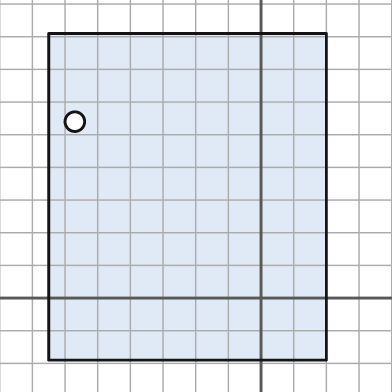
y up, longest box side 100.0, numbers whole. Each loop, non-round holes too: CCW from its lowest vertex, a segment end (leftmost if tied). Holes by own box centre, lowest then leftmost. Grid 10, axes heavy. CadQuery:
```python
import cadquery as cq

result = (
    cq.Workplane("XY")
    .moveTo(-65.0, -19.0)
    .lineTo(20.0, -19.0)
    .lineTo(20.0, 81.0)
    .lineTo(-65.0, 81.0)
    .close()
    .moveTo(-57.0, 54.0)
    .circle(3.0)
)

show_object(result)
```